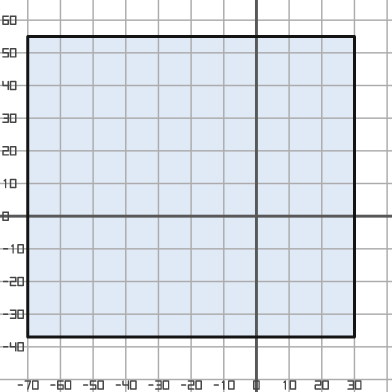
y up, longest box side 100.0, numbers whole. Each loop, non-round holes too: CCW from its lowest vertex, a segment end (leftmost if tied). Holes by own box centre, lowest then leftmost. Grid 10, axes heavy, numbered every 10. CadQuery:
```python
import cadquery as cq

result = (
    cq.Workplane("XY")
    .moveTo(-70.0, -37.0)
    .lineTo(30.0, -37.0)
    .lineTo(30.0, 55.0)
    .lineTo(-70.0, 55.0)
    .close()
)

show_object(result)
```